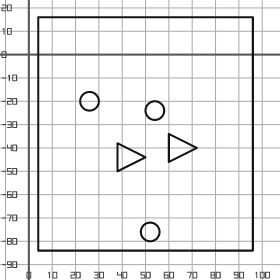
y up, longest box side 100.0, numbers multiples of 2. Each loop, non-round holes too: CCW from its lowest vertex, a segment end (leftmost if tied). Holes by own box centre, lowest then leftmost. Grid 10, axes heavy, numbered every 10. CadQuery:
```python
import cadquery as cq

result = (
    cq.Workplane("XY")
    .moveTo(4.0, -84.0)
    .lineTo(96.0, -84.0)
    .lineTo(96.0, 16.0)
    .lineTo(4.0, 16.0)
    .close()
    .moveTo(52.0, -76.0)
    .circle(4.0)
    .moveTo(38.0, -50.0)
    .lineTo(50.0, -44.0)
    .lineTo(38.0, -38.0)
    .close()
    .moveTo(60.0, -46.0)
    .lineTo(72.0, -40.0)
    .lineTo(60.0, -34.0)
    .close()
    .moveTo(54.0, -24.0)
    .circle(4.0)
    .moveTo(26.0, -20.0)
    .circle(4.0)
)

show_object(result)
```